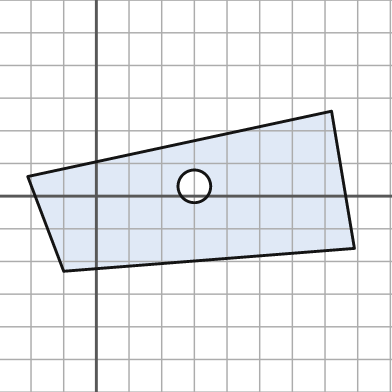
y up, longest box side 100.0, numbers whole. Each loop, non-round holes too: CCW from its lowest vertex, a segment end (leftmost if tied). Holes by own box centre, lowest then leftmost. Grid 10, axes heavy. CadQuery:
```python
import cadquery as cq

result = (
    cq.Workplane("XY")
    .moveTo(-10.0, -23.0)
    .lineTo(79.0, -16.0)
    .lineTo(72.0, 26.0)
    .lineTo(-21.0, 6.0)
    .close()
    .moveTo(30.0, 3.0)
    .circle(5.0)
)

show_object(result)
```